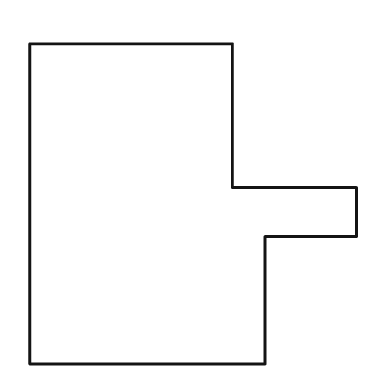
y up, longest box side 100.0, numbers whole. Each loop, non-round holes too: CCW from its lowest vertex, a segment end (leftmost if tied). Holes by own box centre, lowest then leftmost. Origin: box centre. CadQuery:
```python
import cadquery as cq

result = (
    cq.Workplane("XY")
    .moveTo(-50.0, -49.0)
    .lineTo(22.0, -49.0)
    .lineTo(22.0, -10.0)
    .lineTo(50.0, -10.0)
    .lineTo(50.0, 5.0)
    .lineTo(12.0, 5.0)
    .lineTo(12.0, 49.0)
    .lineTo(-50.0, 49.0)
    .close()
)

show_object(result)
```